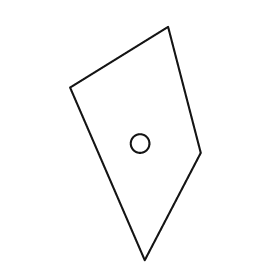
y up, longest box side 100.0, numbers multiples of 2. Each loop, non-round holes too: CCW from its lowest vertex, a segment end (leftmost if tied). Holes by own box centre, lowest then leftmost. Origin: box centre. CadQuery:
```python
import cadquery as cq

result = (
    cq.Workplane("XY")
    .moveTo(4.0, -50.0)
    .lineTo(28.0, -4.0)
    .lineTo(14.0, 50.0)
    .lineTo(-28.0, 24.0)
    .close()
    .moveTo(2.0, 0.0)
    .circle(4.0)
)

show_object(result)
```